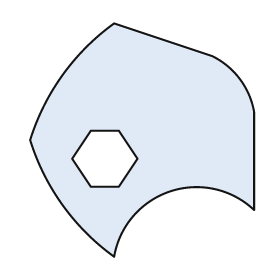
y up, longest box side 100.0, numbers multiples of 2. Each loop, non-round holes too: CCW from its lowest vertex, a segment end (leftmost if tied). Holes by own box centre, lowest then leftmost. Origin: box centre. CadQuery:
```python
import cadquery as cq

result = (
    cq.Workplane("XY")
    .moveTo(-12.0, -50.0)
    .threePointArc((12.0, -22.0), (48.0, -30.0))
    .lineTo(48.0, 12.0)
    .threePointArc((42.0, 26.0), (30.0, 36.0))
    .lineTo(-12.0, 50.0)
    .threePointArc((-34.0, 28.0), (-48.0, 0.0))
    .threePointArc((-34.0, -28.0), (-12.0, -50.0))
    .close()
    .moveTo(-22.0, -20.0)
    .lineTo(-10.0, -20.0)
    .lineTo(-2.0, -8.0)
    .lineTo(-10.0, 4.0)
    .lineTo(-22.0, 4.0)
    .lineTo(-30.0, -8.0)
    .close()
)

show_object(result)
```